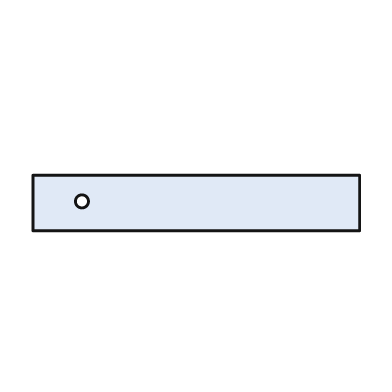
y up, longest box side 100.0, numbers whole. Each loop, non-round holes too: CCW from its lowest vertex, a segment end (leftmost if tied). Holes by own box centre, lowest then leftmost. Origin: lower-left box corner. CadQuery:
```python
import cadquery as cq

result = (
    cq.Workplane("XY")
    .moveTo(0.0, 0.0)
    .lineTo(100.0, 0.0)
    .lineTo(100.0, 17.0)
    .lineTo(0.0, 17.0)
    .close()
    .moveTo(15.0, 9.0)
    .circle(2.0)
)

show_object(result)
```